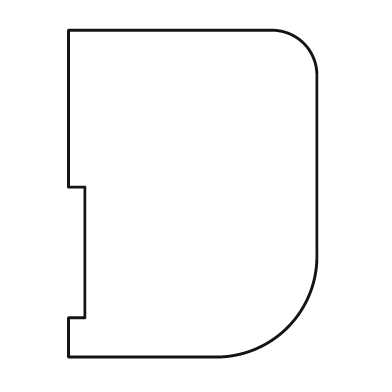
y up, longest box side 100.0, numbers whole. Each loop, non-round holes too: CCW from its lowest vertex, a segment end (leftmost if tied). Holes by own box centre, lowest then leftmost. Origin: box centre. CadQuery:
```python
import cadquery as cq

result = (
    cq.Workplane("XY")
    .moveTo(-38.0, -50.0)
    .lineTo(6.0, -50.0)
    .threePointArc((29.0, -41.0), (38.0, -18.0))
    .lineTo(38.0, 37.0)
    .threePointArc((34.0, 46.0), (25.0, 50.0))
    .lineTo(-38.0, 50.0)
    .lineTo(-38.0, 2.0)
    .lineTo(-33.0, 2.0)
    .lineTo(-33.0, -38.0)
    .lineTo(-38.0, -38.0)
    .close()
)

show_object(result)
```